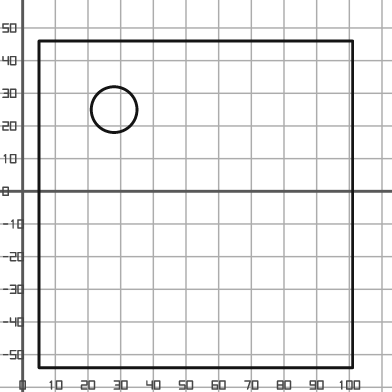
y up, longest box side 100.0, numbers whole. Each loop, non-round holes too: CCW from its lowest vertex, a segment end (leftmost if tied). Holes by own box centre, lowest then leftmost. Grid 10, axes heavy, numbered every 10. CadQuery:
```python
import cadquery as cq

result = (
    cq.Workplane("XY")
    .moveTo(5.0, -54.0)
    .lineTo(101.0, -54.0)
    .lineTo(101.0, 46.0)
    .lineTo(5.0, 46.0)
    .close()
    .moveTo(28.0, 25.0)
    .circle(7.0)
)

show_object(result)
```